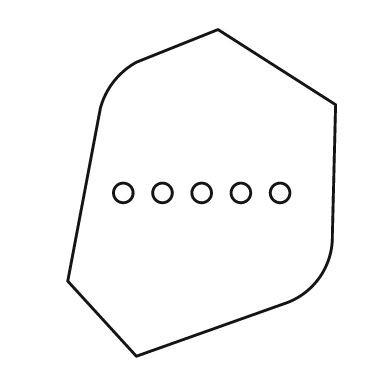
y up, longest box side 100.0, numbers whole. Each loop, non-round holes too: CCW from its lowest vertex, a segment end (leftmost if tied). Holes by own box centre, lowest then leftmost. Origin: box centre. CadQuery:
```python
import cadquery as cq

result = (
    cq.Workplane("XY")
    .moveTo(-20.0, -50.0)
    .lineTo(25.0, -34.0)
    .threePointArc((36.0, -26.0), (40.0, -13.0))
    .lineTo(41.0, 27.0)
    .lineTo(5.0, 50.0)
    .lineTo(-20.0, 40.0)
    .threePointArc((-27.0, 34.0), (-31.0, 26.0))
    .lineTo(-41.0, -27.0)
    .close()
    .moveTo(-24.0, 0.0)
    .circle(3.0)
    .moveTo(-12.0, 0.0)
    .circle(3.0)
    .moveTo(0.0, 0.0)
    .circle(3.0)
    .moveTo(12.0, 0.0)
    .circle(3.0)
    .moveTo(24.0, 0.0)
    .circle(3.0)
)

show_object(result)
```